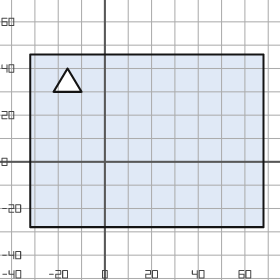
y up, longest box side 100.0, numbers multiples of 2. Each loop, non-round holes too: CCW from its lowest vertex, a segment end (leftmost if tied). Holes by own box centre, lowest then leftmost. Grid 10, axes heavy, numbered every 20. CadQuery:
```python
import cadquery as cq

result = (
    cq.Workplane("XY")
    .moveTo(-32.0, -28.0)
    .lineTo(68.0, -28.0)
    .lineTo(68.0, 46.0)
    .lineTo(-32.0, 46.0)
    .close()
    .moveTo(-22.0, 30.0)
    .lineTo(-10.0, 30.0)
    .lineTo(-16.0, 40.0)
    .close()
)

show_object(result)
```